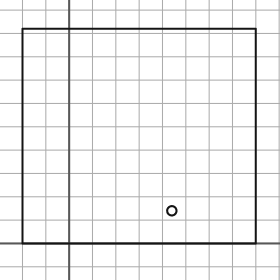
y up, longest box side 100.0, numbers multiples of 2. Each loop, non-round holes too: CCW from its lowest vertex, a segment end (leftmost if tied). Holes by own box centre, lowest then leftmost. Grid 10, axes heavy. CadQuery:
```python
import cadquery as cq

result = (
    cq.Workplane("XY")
    .moveTo(-20.0, 0.0)
    .lineTo(80.0, 0.0)
    .lineTo(80.0, 92.0)
    .lineTo(-20.0, 92.0)
    .close()
    .moveTo(44.0, 14.0)
    .circle(2.0)
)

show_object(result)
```